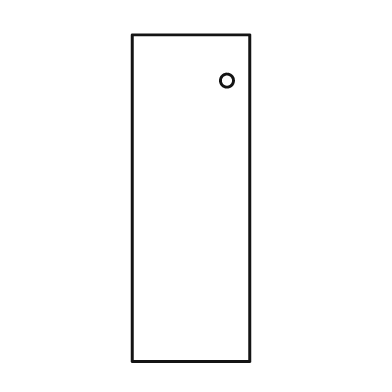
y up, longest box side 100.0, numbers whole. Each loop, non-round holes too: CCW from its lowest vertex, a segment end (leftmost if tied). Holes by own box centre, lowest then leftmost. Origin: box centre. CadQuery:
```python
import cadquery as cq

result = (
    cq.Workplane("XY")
    .moveTo(-18.0, -50.0)
    .lineTo(18.0, -50.0)
    .lineTo(18.0, 50.0)
    .lineTo(-18.0, 50.0)
    .close()
    .moveTo(11.0, 36.0)
    .circle(2.0)
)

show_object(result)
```